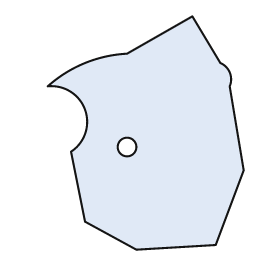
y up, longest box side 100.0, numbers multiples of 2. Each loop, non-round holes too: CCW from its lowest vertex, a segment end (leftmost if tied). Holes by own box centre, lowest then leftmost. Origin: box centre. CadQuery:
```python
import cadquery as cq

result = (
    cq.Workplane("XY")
    .moveTo(-4.0, -50.0)
    .lineTo(30.0, -48.0)
    .lineTo(42.0, -16.0)
    .lineTo(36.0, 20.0)
    .threePointArc((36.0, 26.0), (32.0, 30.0))
    .lineTo(20.0, 50.0)
    .lineTo(-8.0, 34.0)
    .threePointArc((-26.0, 30.0), (-42.0, 20.0))
    .threePointArc((-26.0, 10.0), (-32.0, -8.0))
    .lineTo(-26.0, -38.0)
    .close()
    .moveTo(-8.0, -6.0)
    .circle(4.0)
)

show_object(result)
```